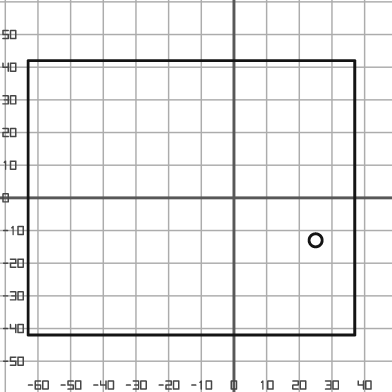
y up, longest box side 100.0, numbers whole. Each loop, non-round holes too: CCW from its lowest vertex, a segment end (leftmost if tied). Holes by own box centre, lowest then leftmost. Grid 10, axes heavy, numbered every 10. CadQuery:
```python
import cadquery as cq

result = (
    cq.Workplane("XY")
    .moveTo(-63.0, -42.0)
    .lineTo(37.0, -42.0)
    .lineTo(37.0, 42.0)
    .lineTo(-63.0, 42.0)
    .close()
    .moveTo(25.0, -13.0)
    .circle(2.0)
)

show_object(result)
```